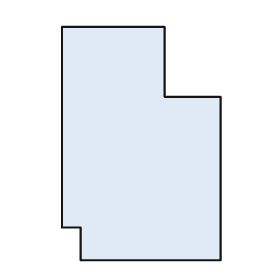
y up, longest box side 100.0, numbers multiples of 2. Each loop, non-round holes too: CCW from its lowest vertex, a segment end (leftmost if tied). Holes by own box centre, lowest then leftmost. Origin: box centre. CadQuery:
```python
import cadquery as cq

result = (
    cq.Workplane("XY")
    .moveTo(-26.0, -50.0)
    .lineTo(34.0, -50.0)
    .lineTo(34.0, 20.0)
    .lineTo(10.0, 20.0)
    .lineTo(10.0, 50.0)
    .lineTo(-34.0, 50.0)
    .lineTo(-34.0, -36.0)
    .lineTo(-26.0, -36.0)
    .close()
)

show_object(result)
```